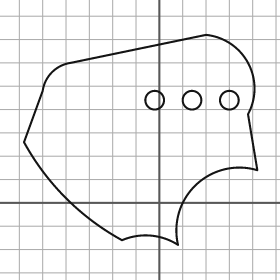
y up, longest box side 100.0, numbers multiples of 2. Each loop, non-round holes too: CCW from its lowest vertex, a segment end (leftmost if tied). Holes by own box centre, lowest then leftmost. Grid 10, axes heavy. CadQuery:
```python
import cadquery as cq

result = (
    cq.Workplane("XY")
    .moveTo(8.0, -18.0)
    .threePointArc((16.0, 8.0), (42.0, 14.0))
    .lineTo(38.0, 38.0)
    .threePointArc((38.0, 60.0), (20.0, 72.0))
    .lineTo(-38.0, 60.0)
    .threePointArc((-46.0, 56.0), (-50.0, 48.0))
    .lineTo(-58.0, 26.0)
    .threePointArc((-40.0, 2.0), (-16.0, -16.0))
    .threePointArc((-4.0, -14.0), (8.0, -18.0))
    .close()
    .moveTo(-2.0, 44.0)
    .circle(4.0)
    .moveTo(14.0, 44.0)
    .circle(4.0)
    .moveTo(30.0, 44.0)
    .circle(4.0)
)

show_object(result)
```